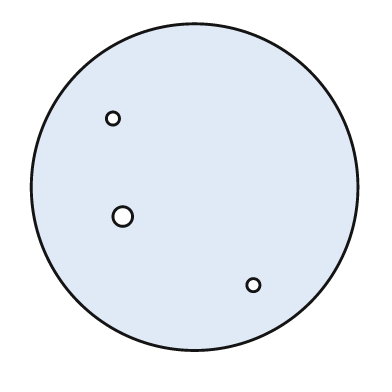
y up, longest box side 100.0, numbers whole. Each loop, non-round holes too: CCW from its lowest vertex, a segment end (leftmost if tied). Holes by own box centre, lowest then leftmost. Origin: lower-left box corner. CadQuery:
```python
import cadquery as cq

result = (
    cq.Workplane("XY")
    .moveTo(50.0, 50.0)
    .circle(50.0)
    .moveTo(68.0, 20.0)
    .circle(2.0)
    .moveTo(28.0, 41.0)
    .circle(3.0)
    .moveTo(25.0, 71.0)
    .circle(2.0)
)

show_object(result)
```